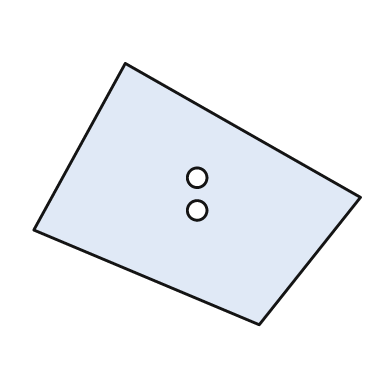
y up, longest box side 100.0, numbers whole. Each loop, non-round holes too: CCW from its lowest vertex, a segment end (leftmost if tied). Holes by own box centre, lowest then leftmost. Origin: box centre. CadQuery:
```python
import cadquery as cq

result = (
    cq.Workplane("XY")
    .moveTo(19.0, -40.0)
    .lineTo(50.0, -1.0)
    .lineTo(-22.0, 40.0)
    .lineTo(-50.0, -11.0)
    .close()
    .moveTo(0.0, -5.0)
    .circle(3.0)
    .moveTo(0.0, 5.0)
    .circle(3.0)
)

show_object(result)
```